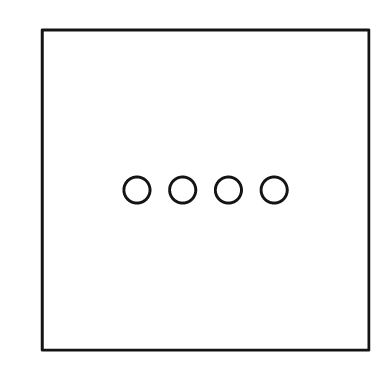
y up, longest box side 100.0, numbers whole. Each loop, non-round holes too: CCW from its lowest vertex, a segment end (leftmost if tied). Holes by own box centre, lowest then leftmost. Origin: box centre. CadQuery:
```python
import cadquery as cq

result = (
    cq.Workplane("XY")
    .moveTo(-50.0, -49.0)
    .lineTo(50.0, -49.0)
    .lineTo(50.0, 49.0)
    .lineTo(-50.0, 49.0)
    .close()
    .moveTo(-21.0, 0.0)
    .circle(4.0)
    .moveTo(-7.0, 0.0)
    .circle(4.0)
    .moveTo(7.0, 0.0)
    .circle(4.0)
    .moveTo(21.0, 0.0)
    .circle(4.0)
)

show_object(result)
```